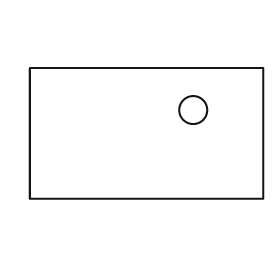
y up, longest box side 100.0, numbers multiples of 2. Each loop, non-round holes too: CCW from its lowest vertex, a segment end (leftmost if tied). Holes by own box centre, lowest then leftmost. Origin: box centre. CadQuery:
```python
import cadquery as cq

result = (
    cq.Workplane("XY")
    .moveTo(-50.0, -28.0)
    .lineTo(50.0, -28.0)
    .lineTo(50.0, 28.0)
    .lineTo(-50.0, 28.0)
    .close()
    .moveTo(20.0, 10.0)
    .circle(6.0)
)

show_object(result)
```